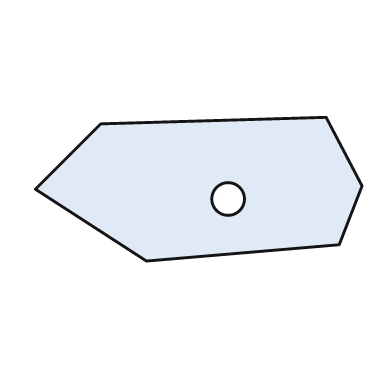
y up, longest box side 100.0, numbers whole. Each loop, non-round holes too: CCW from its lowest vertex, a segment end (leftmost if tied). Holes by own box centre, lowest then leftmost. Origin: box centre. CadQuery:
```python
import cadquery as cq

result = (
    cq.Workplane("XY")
    .moveTo(-16.0, -22.0)
    .lineTo(43.0, -17.0)
    .lineTo(50.0, 1.0)
    .lineTo(39.0, 22.0)
    .lineTo(-30.0, 20.0)
    .lineTo(-50.0, 0.0)
    .close()
    .moveTo(9.0, -3.0)
    .circle(5.0)
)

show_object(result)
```